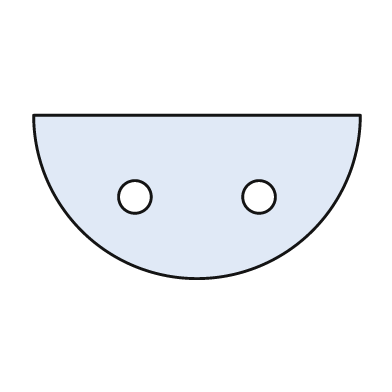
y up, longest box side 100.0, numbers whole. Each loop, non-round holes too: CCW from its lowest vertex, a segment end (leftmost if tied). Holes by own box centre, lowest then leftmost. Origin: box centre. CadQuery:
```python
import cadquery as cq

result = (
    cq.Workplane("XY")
    .moveTo(-50.0, 25.0)
    .threePointArc((0.0, -25.0), (50.0, 25.0))
    .close()
    .moveTo(-19.0, 0.0)
    .circle(5.0)
    .moveTo(19.0, 0.0)
    .circle(5.0)
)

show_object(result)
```